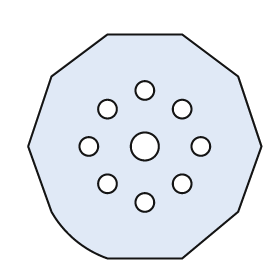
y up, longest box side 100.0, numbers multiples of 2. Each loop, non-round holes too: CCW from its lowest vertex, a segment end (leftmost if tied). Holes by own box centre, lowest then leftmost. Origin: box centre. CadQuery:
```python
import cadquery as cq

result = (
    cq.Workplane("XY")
    .moveTo(-16.0, -48.0)
    .lineTo(16.0, -48.0)
    .lineTo(40.0, -28.0)
    .lineTo(50.0, 0.0)
    .lineTo(40.0, 30.0)
    .lineTo(16.0, 48.0)
    .lineTo(-16.0, 48.0)
    .lineTo(-40.0, 30.0)
    .lineTo(-50.0, 0.0)
    .lineTo(-40.0, -28.0)
    .threePointArc((-30.0, -40.0), (-16.0, -48.0))
    .close()
    .moveTo(0.0, -24.0)
    .circle(4.0)
    .moveTo(-16.0, -16.0)
    .circle(4.0)
    .moveTo(16.0, -16.0)
    .circle(4.0)
    .moveTo(-24.0, 0.0)
    .circle(4.0)
    .moveTo(0.0, 0.0)
    .circle(6.0)
    .moveTo(24.0, 0.0)
    .circle(4.0)
    .moveTo(-16.0, 16.0)
    .circle(4.0)
    .moveTo(16.0, 16.0)
    .circle(4.0)
    .moveTo(0.0, 24.0)
    .circle(4.0)
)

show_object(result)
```